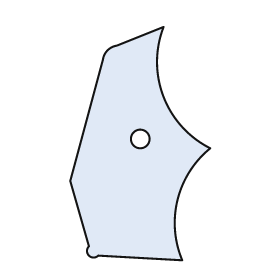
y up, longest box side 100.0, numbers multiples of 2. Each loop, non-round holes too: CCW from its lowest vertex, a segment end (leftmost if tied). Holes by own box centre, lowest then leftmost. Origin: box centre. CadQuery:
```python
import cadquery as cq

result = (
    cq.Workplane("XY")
    .moveTo(18.0, -50.0)
    .threePointArc((16.0, -24.0), (30.0, -2.0))
    .threePointArc((10.0, 20.0), (10.0, 50.0))
    .lineTo(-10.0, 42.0)
    .threePointArc((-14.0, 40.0), (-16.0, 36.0))
    .lineTo(-30.0, -16.0)
    .lineTo(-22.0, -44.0)
    .threePointArc((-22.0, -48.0), (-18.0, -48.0))
    .close()
    .moveTo(0.0, 2.0)
    .circle(4.0)
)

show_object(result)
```